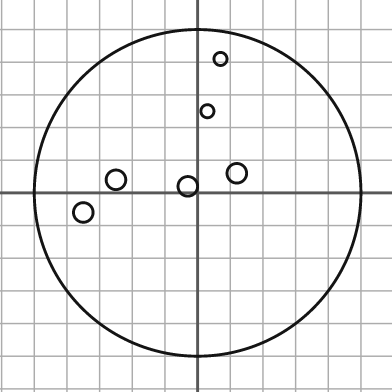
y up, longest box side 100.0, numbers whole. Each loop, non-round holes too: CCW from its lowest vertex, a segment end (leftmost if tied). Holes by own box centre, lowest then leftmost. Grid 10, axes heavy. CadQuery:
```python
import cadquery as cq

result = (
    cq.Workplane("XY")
    .moveTo(0.0, 0.0)
    .circle(50.0)
    .moveTo(-35.0, -6.0)
    .circle(3.0)
    .moveTo(-3.0, 2.0)
    .circle(3.0)
    .moveTo(-25.0, 4.0)
    .circle(3.0)
    .moveTo(12.0, 6.0)
    .circle(3.0)
    .moveTo(3.0, 25.0)
    .circle(2.0)
    .moveTo(7.0, 41.0)
    .circle(2.0)
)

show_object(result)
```